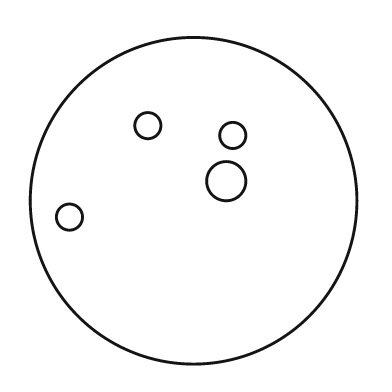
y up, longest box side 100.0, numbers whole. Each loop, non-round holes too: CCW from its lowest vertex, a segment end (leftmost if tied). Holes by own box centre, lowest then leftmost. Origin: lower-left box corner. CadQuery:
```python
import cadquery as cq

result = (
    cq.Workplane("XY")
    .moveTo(50.0, 50.0)
    .circle(50.0)
    .moveTo(12.0, 45.0)
    .circle(4.0)
    .moveTo(60.0, 56.0)
    .circle(6.0)
    .moveTo(62.0, 70.0)
    .circle(4.0)
    .moveTo(36.0, 73.0)
    .circle(4.0)
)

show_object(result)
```